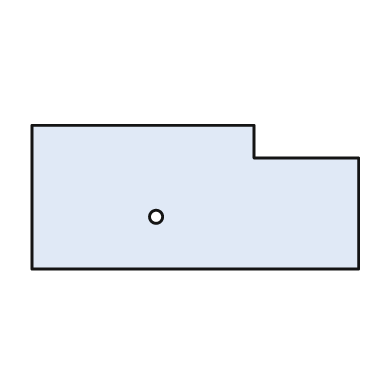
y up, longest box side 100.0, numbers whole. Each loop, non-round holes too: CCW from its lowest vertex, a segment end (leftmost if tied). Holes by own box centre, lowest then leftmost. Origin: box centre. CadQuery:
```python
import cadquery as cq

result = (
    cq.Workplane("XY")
    .moveTo(-50.0, -22.0)
    .lineTo(50.0, -22.0)
    .lineTo(50.0, 12.0)
    .lineTo(18.0, 12.0)
    .lineTo(18.0, 22.0)
    .lineTo(-50.0, 22.0)
    .close()
    .moveTo(-12.0, -6.0)
    .circle(2.0)
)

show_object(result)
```